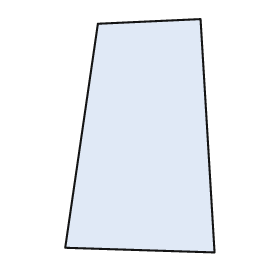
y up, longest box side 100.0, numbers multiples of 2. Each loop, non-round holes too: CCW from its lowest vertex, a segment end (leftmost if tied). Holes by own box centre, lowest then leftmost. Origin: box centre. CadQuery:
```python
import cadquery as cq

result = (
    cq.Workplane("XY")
    .moveTo(32.0, -50.0)
    .lineTo(26.0, 50.0)
    .lineTo(-18.0, 48.0)
    .lineTo(-32.0, -48.0)
    .close()
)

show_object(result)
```